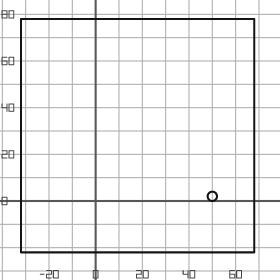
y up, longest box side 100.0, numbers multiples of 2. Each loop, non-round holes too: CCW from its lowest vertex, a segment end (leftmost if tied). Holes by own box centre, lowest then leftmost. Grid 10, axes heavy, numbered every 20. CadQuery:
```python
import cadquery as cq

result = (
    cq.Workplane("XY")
    .moveTo(-32.0, -22.0)
    .lineTo(68.0, -22.0)
    .lineTo(68.0, 78.0)
    .lineTo(-32.0, 78.0)
    .close()
    .moveTo(50.0, 2.0)
    .circle(2.0)
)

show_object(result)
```